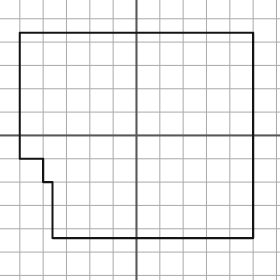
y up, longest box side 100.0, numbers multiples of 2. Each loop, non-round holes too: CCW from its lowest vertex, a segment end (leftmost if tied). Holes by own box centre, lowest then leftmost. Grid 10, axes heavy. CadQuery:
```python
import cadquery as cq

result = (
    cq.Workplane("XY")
    .moveTo(-36.0, -44.0)
    .lineTo(50.0, -44.0)
    .lineTo(50.0, 44.0)
    .lineTo(-50.0, 44.0)
    .lineTo(-50.0, -10.0)
    .lineTo(-40.0, -10.0)
    .lineTo(-40.0, -20.0)
    .lineTo(-36.0, -20.0)
    .close()
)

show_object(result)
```